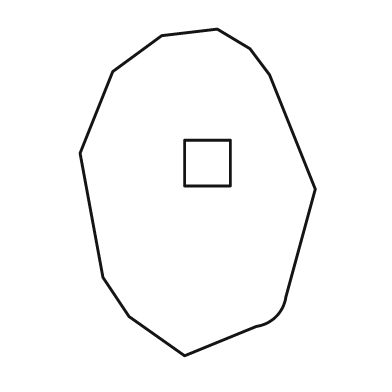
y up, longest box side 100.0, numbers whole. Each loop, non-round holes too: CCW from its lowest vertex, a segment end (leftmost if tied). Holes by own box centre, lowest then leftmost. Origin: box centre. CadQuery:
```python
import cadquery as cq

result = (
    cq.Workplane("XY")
    .moveTo(-4.0, -50.0)
    .lineTo(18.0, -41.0)
    .threePointArc((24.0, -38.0), (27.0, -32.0))
    .lineTo(36.0, 1.0)
    .lineTo(22.0, 36.0)
    .lineTo(16.0, 44.0)
    .lineTo(6.0, 50.0)
    .lineTo(-11.0, 48.0)
    .lineTo(-26.0, 37.0)
    .lineTo(-36.0, 12.0)
    .lineTo(-29.0, -26.0)
    .lineTo(-21.0, -38.0)
    .close()
    .moveTo(-4.0, 2.0)
    .lineTo(10.0, 2.0)
    .lineTo(10.0, 16.0)
    .lineTo(-4.0, 16.0)
    .close()
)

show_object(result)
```